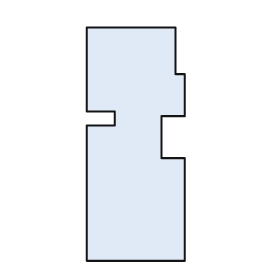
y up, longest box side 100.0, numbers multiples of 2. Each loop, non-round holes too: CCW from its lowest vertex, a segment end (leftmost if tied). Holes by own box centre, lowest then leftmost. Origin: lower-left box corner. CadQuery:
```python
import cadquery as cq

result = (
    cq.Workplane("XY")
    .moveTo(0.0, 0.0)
    .lineTo(42.0, 0.0)
    .lineTo(42.0, 44.0)
    .lineTo(32.0, 44.0)
    .lineTo(32.0, 62.0)
    .lineTo(42.0, 62.0)
    .lineTo(42.0, 80.0)
    .lineTo(38.0, 80.0)
    .lineTo(38.0, 100.0)
    .lineTo(0.0, 100.0)
    .lineTo(0.0, 64.0)
    .lineTo(12.0, 64.0)
    .lineTo(12.0, 58.0)
    .lineTo(0.0, 58.0)
    .close()
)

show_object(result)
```